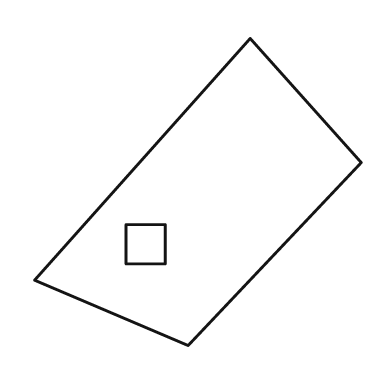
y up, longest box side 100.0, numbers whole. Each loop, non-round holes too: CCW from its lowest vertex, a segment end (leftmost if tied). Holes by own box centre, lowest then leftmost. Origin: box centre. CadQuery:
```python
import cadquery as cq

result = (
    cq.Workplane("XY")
    .moveTo(-3.0, -47.0)
    .lineTo(50.0, 9.0)
    .lineTo(16.0, 47.0)
    .lineTo(-50.0, -27.0)
    .close()
    .moveTo(-22.0, -22.0)
    .lineTo(-10.0, -22.0)
    .lineTo(-10.0, -10.0)
    .lineTo(-22.0, -10.0)
    .close()
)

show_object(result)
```